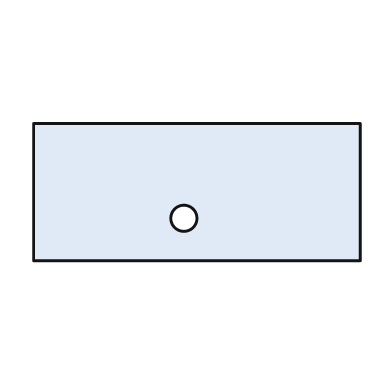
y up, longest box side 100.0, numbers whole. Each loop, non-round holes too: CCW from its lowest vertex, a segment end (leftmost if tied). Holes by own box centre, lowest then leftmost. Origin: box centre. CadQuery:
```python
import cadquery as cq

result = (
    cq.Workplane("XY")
    .moveTo(-50.0, -21.0)
    .lineTo(50.0, -21.0)
    .lineTo(50.0, 21.0)
    .lineTo(-50.0, 21.0)
    .close()
    .moveTo(-4.0, -8.0)
    .circle(4.0)
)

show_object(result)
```